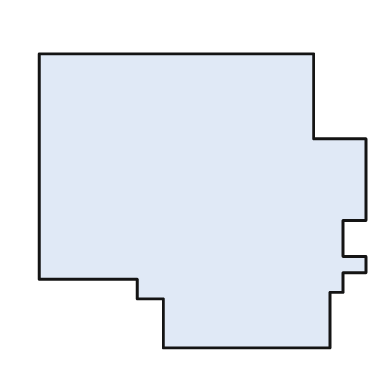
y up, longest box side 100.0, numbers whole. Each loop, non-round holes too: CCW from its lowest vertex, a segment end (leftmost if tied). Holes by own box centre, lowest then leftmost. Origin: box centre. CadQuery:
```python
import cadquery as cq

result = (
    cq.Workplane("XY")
    .moveTo(-12.0, -45.0)
    .lineTo(39.0, -45.0)
    .lineTo(39.0, -28.0)
    .lineTo(43.0, -28.0)
    .lineTo(43.0, -22.0)
    .lineTo(50.0, -22.0)
    .lineTo(50.0, -17.0)
    .lineTo(43.0, -17.0)
    .lineTo(43.0, -6.0)
    .lineTo(50.0, -6.0)
    .lineTo(50.0, 19.0)
    .lineTo(34.0, 19.0)
    .lineTo(34.0, 45.0)
    .lineTo(-50.0, 45.0)
    .lineTo(-50.0, -24.0)
    .lineTo(-20.0, -24.0)
    .lineTo(-20.0, -30.0)
    .lineTo(-12.0, -30.0)
    .close()
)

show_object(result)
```